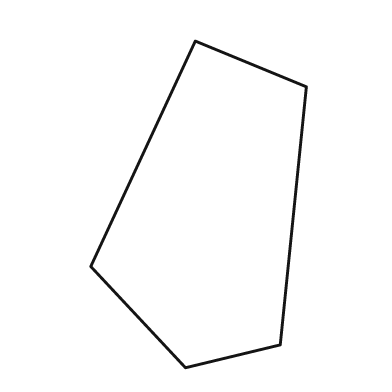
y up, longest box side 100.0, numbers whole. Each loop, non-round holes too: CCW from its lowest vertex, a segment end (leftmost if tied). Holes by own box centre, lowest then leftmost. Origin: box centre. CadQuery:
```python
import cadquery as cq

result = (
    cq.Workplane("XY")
    .moveTo(-4.0, -50.0)
    .lineTo(25.0, -43.0)
    .lineTo(33.0, 36.0)
    .lineTo(-1.0, 50.0)
    .lineTo(-33.0, -19.0)
    .close()
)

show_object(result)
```